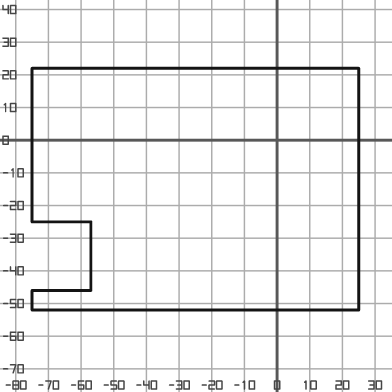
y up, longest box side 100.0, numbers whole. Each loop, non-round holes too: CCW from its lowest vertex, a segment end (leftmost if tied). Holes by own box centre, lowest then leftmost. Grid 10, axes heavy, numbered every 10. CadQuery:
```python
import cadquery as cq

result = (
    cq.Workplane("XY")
    .moveTo(-75.0, -52.0)
    .lineTo(25.0, -52.0)
    .lineTo(25.0, 22.0)
    .lineTo(-75.0, 22.0)
    .lineTo(-75.0, -25.0)
    .lineTo(-57.0, -25.0)
    .lineTo(-57.0, -46.0)
    .lineTo(-75.0, -46.0)
    .close()
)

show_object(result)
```